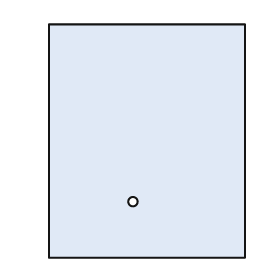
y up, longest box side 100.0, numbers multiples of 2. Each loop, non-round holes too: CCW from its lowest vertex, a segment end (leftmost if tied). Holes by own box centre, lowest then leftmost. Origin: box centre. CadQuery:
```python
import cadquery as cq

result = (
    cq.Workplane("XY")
    .moveTo(-42.0, -50.0)
    .lineTo(42.0, -50.0)
    .lineTo(42.0, 50.0)
    .lineTo(-42.0, 50.0)
    .close()
    .moveTo(-6.0, -26.0)
    .circle(2.0)
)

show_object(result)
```